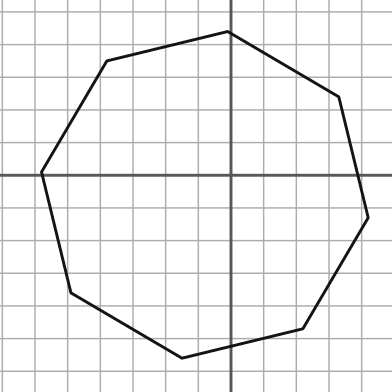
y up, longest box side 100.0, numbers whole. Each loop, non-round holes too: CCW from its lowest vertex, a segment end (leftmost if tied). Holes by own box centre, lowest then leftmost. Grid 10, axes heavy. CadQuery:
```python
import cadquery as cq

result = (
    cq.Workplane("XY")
    .moveTo(-15.0, -56.0)
    .lineTo(22.0, -47.0)
    .lineTo(42.0, -13.0)
    .lineTo(33.0, 24.0)
    .lineTo(-1.0, 44.0)
    .lineTo(-38.0, 35.0)
    .lineTo(-58.0, 1.0)
    .lineTo(-49.0, -36.0)
    .close()
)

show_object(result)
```